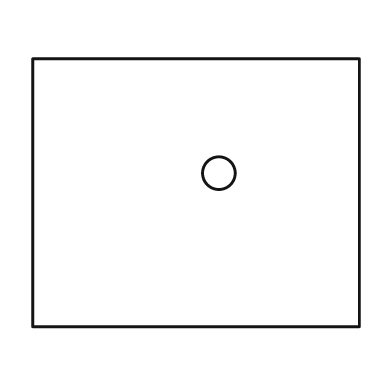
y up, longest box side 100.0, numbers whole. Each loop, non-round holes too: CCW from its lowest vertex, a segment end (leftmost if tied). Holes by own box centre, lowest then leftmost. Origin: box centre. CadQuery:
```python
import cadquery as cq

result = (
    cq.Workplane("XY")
    .moveTo(-50.0, -41.0)
    .lineTo(50.0, -41.0)
    .lineTo(50.0, 41.0)
    .lineTo(-50.0, 41.0)
    .close()
    .moveTo(7.0, 6.0)
    .circle(5.0)
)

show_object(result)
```